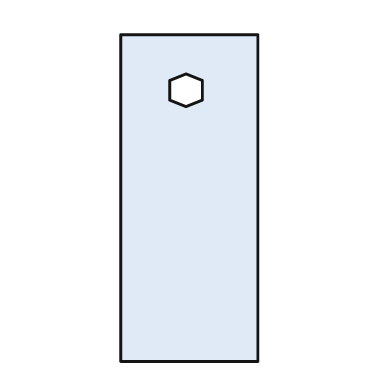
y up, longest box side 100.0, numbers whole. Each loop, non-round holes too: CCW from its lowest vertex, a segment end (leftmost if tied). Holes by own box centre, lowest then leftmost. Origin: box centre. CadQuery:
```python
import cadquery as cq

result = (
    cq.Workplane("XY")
    .moveTo(-21.0, -50.0)
    .lineTo(21.0, -50.0)
    .lineTo(21.0, 50.0)
    .lineTo(-21.0, 50.0)
    .close()
    .moveTo(-1.0, 28.0)
    .lineTo(4.0, 30.0)
    .lineTo(4.0, 36.0)
    .lineTo(-1.0, 38.0)
    .lineTo(-6.0, 36.0)
    .lineTo(-6.0, 30.0)
    .close()
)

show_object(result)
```